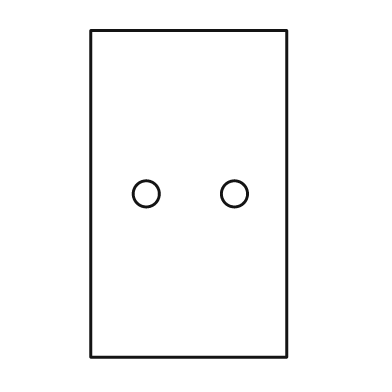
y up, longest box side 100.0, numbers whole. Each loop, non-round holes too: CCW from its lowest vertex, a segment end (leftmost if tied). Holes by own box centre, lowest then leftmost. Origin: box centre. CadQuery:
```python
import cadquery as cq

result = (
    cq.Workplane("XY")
    .moveTo(-30.0, -50.0)
    .lineTo(30.0, -50.0)
    .lineTo(30.0, 50.0)
    .lineTo(-30.0, 50.0)
    .close()
    .moveTo(-13.0, 0.0)
    .circle(4.0)
    .moveTo(14.0, 0.0)
    .circle(4.0)
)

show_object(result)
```